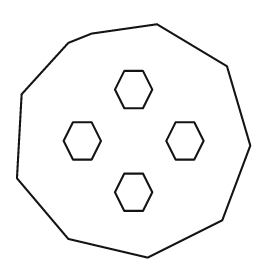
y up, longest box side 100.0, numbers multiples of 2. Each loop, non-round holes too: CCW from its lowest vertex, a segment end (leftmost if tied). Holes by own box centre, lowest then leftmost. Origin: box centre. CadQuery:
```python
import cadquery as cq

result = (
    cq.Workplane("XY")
    .moveTo(6.0, -50.0)
    .lineTo(38.0, -34.0)
    .lineTo(50.0, -2.0)
    .lineTo(40.0, 32.0)
    .lineTo(10.0, 50.0)
    .lineTo(-18.0, 46.0)
    .lineTo(-28.0, 42.0)
    .lineTo(-48.0, 20.0)
    .lineTo(-50.0, -16.0)
    .lineTo(-28.0, -42.0)
    .close()
    .moveTo(-4.0, -30.0)
    .lineTo(4.0, -30.0)
    .lineTo(8.0, -22.0)
    .lineTo(4.0, -14.0)
    .lineTo(-4.0, -14.0)
    .lineTo(-8.0, -22.0)
    .close()
    .moveTo(-26.0, -8.0)
    .lineTo(-18.0, -8.0)
    .lineTo(-14.0, 0.0)
    .lineTo(-18.0, 8.0)
    .lineTo(-26.0, 8.0)
    .lineTo(-30.0, 0.0)
    .close()
    .moveTo(18.0, -8.0)
    .lineTo(26.0, -8.0)
    .lineTo(30.0, 0.0)
    .lineTo(26.0, 8.0)
    .lineTo(18.0, 8.0)
    .lineTo(14.0, 0.0)
    .close()
    .moveTo(-4.0, 14.0)
    .lineTo(4.0, 14.0)
    .lineTo(8.0, 22.0)
    .lineTo(4.0, 30.0)
    .lineTo(-4.0, 30.0)
    .lineTo(-8.0, 22.0)
    .close()
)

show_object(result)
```